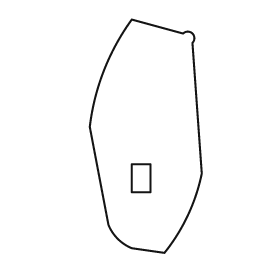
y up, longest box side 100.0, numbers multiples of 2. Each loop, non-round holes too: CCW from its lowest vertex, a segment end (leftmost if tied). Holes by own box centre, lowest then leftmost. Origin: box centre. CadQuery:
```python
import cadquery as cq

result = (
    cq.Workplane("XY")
    .moveTo(8.0, -50.0)
    .threePointArc((18.0, -34.0), (24.0, -16.0))
    .lineTo(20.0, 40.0)
    .threePointArc((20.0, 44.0), (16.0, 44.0))
    .lineTo(-6.0, 50.0)
    .threePointArc((-18.0, 28.0), (-24.0, 4.0))
    .lineTo(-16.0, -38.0)
    .threePointArc((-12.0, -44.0), (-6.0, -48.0))
    .close()
    .moveTo(-6.0, -24.0)
    .lineTo(2.0, -24.0)
    .lineTo(2.0, -12.0)
    .lineTo(-6.0, -12.0)
    .close()
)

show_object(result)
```